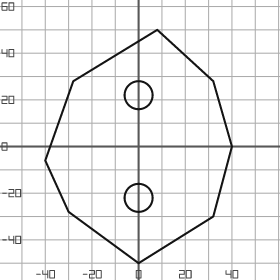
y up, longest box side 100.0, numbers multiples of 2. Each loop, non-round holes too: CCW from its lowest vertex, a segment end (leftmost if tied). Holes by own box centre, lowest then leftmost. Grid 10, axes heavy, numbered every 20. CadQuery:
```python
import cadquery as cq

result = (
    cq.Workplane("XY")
    .moveTo(0.0, -50.0)
    .lineTo(32.0, -30.0)
    .lineTo(40.0, 0.0)
    .lineTo(32.0, 28.0)
    .lineTo(8.0, 50.0)
    .lineTo(-28.0, 28.0)
    .lineTo(-40.0, -6.0)
    .lineTo(-30.0, -28.0)
    .close()
    .moveTo(0.0, -22.0)
    .circle(6.0)
    .moveTo(0.0, 22.0)
    .circle(6.0)
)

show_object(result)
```